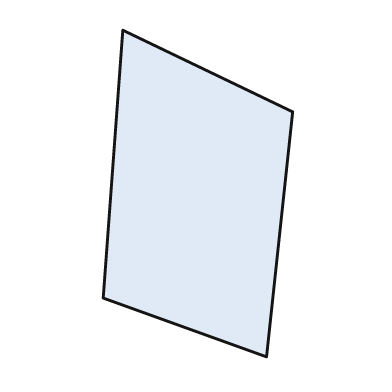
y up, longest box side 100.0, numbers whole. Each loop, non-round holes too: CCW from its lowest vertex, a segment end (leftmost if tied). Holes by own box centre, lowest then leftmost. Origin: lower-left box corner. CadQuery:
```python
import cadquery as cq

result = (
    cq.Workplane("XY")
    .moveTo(50.0, 0.0)
    .lineTo(58.0, 75.0)
    .lineTo(6.0, 100.0)
    .lineTo(0.0, 18.0)
    .close()
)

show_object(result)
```